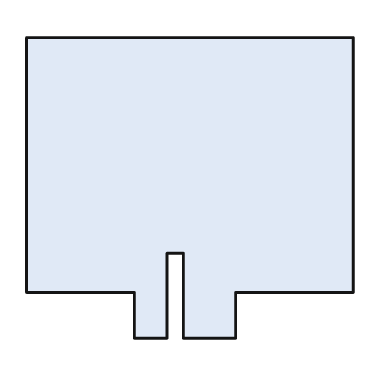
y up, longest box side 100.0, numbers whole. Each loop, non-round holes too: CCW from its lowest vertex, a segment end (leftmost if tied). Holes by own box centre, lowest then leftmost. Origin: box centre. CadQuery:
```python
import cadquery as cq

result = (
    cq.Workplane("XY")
    .moveTo(-17.0, -46.0)
    .lineTo(-7.0, -46.0)
    .lineTo(-7.0, -20.0)
    .lineTo(-2.0, -20.0)
    .lineTo(-2.0, -46.0)
    .lineTo(14.0, -46.0)
    .lineTo(14.0, -32.0)
    .lineTo(50.0, -32.0)
    .lineTo(50.0, 46.0)
    .lineTo(-50.0, 46.0)
    .lineTo(-50.0, -32.0)
    .lineTo(-17.0, -32.0)
    .close()
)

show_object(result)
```